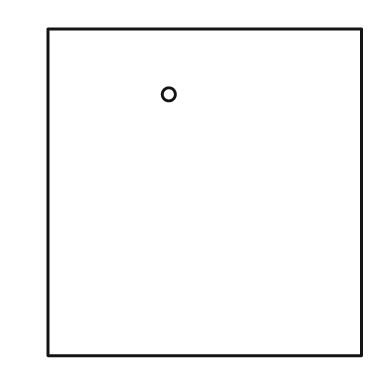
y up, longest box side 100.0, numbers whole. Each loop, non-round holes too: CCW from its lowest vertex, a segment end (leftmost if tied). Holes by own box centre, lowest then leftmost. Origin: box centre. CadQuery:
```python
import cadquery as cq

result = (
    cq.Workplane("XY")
    .moveTo(-48.0, -50.0)
    .lineTo(48.0, -50.0)
    .lineTo(48.0, 50.0)
    .lineTo(-48.0, 50.0)
    .close()
    .moveTo(-11.0, 30.0)
    .circle(2.0)
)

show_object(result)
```